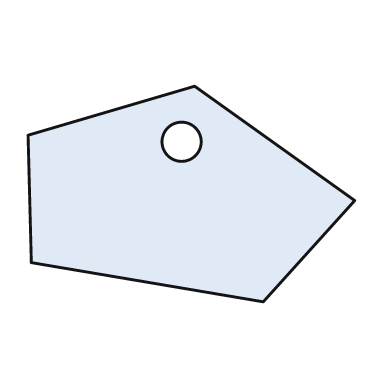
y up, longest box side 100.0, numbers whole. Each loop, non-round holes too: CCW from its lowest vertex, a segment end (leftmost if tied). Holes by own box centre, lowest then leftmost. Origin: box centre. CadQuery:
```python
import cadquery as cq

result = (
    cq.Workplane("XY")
    .moveTo(22.0, -33.0)
    .lineTo(50.0, -2.0)
    .lineTo(1.0, 33.0)
    .lineTo(-50.0, 18.0)
    .lineTo(-49.0, -21.0)
    .close()
    .moveTo(-3.0, 16.0)
    .circle(6.0)
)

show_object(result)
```